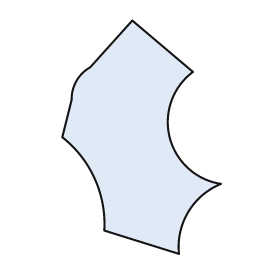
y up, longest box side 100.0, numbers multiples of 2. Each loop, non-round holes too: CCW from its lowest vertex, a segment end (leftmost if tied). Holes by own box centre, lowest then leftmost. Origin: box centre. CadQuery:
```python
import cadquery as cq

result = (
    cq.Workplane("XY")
    .moveTo(16.0, -50.0)
    .threePointArc((20.0, -32.0), (34.0, -20.0))
    .threePointArc((12.0, 0.0), (22.0, 28.0))
    .lineTo(-4.0, 50.0)
    .lineTo(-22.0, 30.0)
    .threePointArc((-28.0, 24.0), (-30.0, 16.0))
    .lineTo(-34.0, 0.0)
    .threePointArc((-20.0, -18.0), (-16.0, -40.0))
    .close()
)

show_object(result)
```